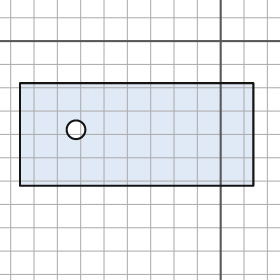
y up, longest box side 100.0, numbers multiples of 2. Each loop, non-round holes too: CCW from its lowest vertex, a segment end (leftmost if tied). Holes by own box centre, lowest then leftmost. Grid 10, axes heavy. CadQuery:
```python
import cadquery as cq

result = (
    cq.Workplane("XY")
    .moveTo(-86.0, -62.0)
    .lineTo(14.0, -62.0)
    .lineTo(14.0, -18.0)
    .lineTo(-86.0, -18.0)
    .close()
    .moveTo(-62.0, -38.0)
    .circle(4.0)
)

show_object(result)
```